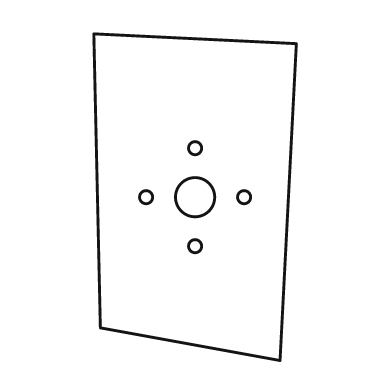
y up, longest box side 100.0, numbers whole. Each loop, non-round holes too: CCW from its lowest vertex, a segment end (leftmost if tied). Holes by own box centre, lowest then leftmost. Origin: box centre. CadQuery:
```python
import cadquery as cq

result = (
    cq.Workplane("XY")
    .moveTo(26.0, -50.0)
    .lineTo(31.0, 47.0)
    .lineTo(-31.0, 50.0)
    .lineTo(-29.0, -40.0)
    .close()
    .moveTo(0.0, -15.0)
    .circle(2.0)
    .moveTo(-15.0, 0.0)
    .circle(2.0)
    .moveTo(0.0, 0.0)
    .circle(6.0)
    .moveTo(15.0, 0.0)
    .circle(2.0)
    .moveTo(0.0, 15.0)
    .circle(2.0)
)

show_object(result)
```